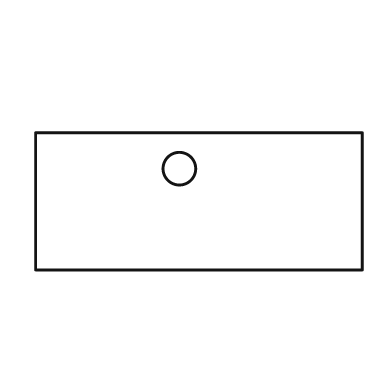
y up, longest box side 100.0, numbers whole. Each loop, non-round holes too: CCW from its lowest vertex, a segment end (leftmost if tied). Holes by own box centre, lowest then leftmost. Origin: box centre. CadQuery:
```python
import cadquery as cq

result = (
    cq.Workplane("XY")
    .moveTo(-50.0, -21.0)
    .lineTo(50.0, -21.0)
    .lineTo(50.0, 21.0)
    .lineTo(-50.0, 21.0)
    .close()
    .moveTo(-6.0, 10.0)
    .circle(5.0)
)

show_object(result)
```